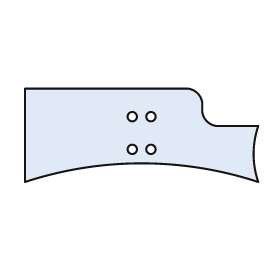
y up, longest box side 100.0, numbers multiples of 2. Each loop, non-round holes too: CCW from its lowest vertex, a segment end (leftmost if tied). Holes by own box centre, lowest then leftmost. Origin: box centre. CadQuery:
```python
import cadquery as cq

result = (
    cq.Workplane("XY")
    .moveTo(-50.0, -20.0)
    .threePointArc((0.0, -12.0), (50.0, -20.0))
    .threePointArc((48.0, -8.0), (50.0, 4.0))
    .lineTo(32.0, 4.0)
    .threePointArc((28.0, 6.0), (26.0, 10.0))
    .lineTo(26.0, 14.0)
    .threePointArc((24.0, 18.0), (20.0, 20.0))
    .lineTo(-50.0, 20.0)
    .close()
    .moveTo(-4.0, -6.0)
    .circle(2.0)
    .moveTo(4.0, -6.0)
    .circle(2.0)
    .moveTo(-4.0, 8.0)
    .circle(2.0)
    .moveTo(4.0, 8.0)
    .circle(2.0)
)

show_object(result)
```